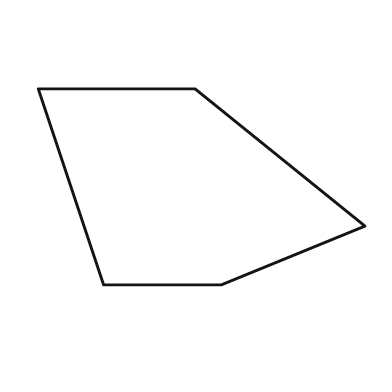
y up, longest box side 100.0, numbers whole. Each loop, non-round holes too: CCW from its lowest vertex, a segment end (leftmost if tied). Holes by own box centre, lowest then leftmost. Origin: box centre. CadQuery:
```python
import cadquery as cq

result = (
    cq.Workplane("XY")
    .moveTo(-30.0, -30.0)
    .lineTo(6.0, -30.0)
    .lineTo(50.0, -12.0)
    .lineTo(-2.0, 30.0)
    .lineTo(-50.0, 30.0)
    .close()
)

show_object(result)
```